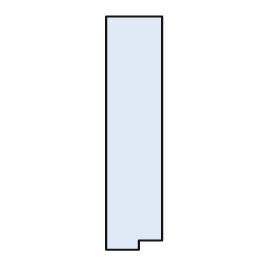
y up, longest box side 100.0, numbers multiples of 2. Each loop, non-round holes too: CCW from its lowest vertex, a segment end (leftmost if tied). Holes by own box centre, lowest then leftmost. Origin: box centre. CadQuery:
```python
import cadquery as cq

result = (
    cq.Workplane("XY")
    .moveTo(-12.0, -50.0)
    .lineTo(2.0, -50.0)
    .lineTo(2.0, -46.0)
    .lineTo(12.0, -46.0)
    .lineTo(12.0, 50.0)
    .lineTo(-12.0, 50.0)
    .close()
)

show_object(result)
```